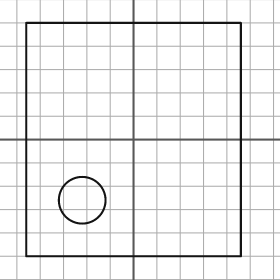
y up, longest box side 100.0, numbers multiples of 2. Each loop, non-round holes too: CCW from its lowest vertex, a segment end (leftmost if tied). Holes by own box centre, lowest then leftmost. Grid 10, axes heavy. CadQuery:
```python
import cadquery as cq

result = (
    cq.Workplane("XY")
    .moveTo(-46.0, -50.0)
    .lineTo(46.0, -50.0)
    .lineTo(46.0, 50.0)
    .lineTo(-46.0, 50.0)
    .close()
    .moveTo(-22.0, -26.0)
    .circle(10.0)
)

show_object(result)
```